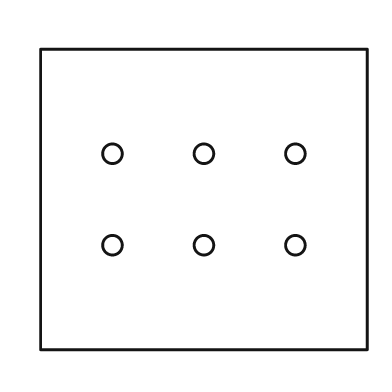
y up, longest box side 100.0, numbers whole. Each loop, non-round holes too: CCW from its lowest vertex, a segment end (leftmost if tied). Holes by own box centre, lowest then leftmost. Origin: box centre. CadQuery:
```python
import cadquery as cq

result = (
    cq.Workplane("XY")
    .moveTo(-50.0, -46.0)
    .lineTo(50.0, -46.0)
    .lineTo(50.0, 46.0)
    .lineTo(-50.0, 46.0)
    .close()
    .moveTo(-28.0, -14.0)
    .circle(3.0)
    .moveTo(0.0, -14.0)
    .circle(3.0)
    .moveTo(28.0, -14.0)
    .circle(3.0)
    .moveTo(-28.0, 14.0)
    .circle(3.0)
    .moveTo(0.0, 14.0)
    .circle(3.0)
    .moveTo(28.0, 14.0)
    .circle(3.0)
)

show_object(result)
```